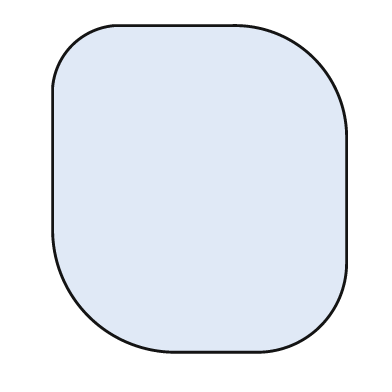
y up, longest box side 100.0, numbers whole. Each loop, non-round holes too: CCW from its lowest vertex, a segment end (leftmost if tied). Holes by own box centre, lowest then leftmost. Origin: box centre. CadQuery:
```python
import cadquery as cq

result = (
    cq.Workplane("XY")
    .moveTo(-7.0, -50.0)
    .lineTo(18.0, -50.0)
    .threePointArc((37.0, -42.0), (45.0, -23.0))
    .lineTo(45.0, 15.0)
    .threePointArc((35.0, 40.0), (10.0, 50.0))
    .lineTo(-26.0, 50.0)
    .threePointArc((-39.0, 44.0), (-45.0, 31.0))
    .lineTo(-45.0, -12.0)
    .threePointArc((-34.0, -39.0), (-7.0, -50.0))
    .close()
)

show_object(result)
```